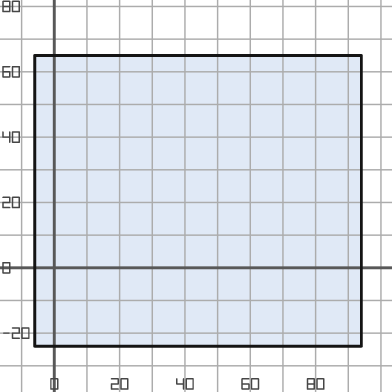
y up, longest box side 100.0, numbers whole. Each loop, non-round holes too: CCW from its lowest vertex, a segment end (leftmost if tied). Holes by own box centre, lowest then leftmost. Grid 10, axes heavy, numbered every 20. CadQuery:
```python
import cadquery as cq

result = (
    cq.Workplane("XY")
    .moveTo(-6.0, -24.0)
    .lineTo(94.0, -24.0)
    .lineTo(94.0, 65.0)
    .lineTo(-6.0, 65.0)
    .close()
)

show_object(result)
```